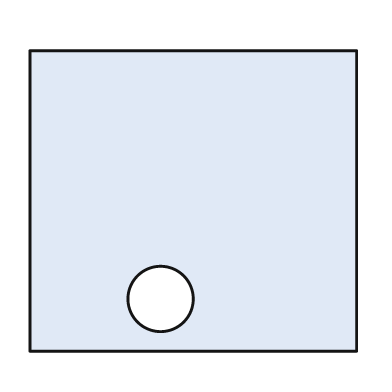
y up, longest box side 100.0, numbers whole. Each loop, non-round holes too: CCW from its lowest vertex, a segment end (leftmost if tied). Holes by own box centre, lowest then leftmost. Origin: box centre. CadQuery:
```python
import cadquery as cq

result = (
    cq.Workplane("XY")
    .moveTo(-50.0, -46.0)
    .lineTo(50.0, -46.0)
    .lineTo(50.0, 46.0)
    .lineTo(-50.0, 46.0)
    .close()
    .moveTo(-10.0, -30.0)
    .circle(10.0)
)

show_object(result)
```